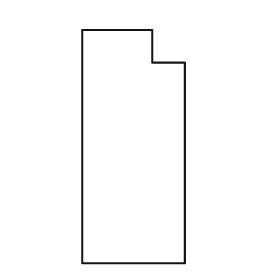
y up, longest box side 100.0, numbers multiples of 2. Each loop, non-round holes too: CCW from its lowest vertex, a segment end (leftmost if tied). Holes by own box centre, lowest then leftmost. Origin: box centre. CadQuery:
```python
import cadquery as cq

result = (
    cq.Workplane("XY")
    .moveTo(-22.0, -50.0)
    .lineTo(22.0, -50.0)
    .lineTo(22.0, 36.0)
    .lineTo(8.0, 36.0)
    .lineTo(8.0, 50.0)
    .lineTo(-22.0, 50.0)
    .close()
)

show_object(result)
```